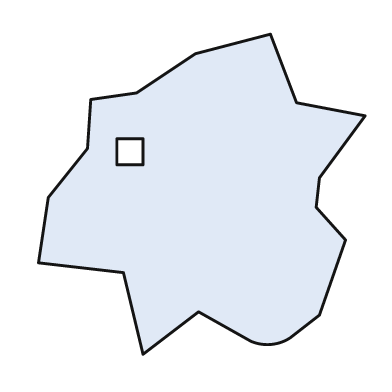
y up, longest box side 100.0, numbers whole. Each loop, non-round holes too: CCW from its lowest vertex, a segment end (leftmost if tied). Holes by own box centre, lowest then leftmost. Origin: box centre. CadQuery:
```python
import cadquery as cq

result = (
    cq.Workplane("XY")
    .moveTo(-18.0, -49.0)
    .lineTo(-1.0, -36.0)
    .lineTo(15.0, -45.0)
    .threePointArc((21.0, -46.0), (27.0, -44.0))
    .lineTo(36.0, -37.0)
    .lineTo(44.0, -14.0)
    .lineTo(35.0, -4.0)
    .lineTo(36.0, 5.0)
    .lineTo(50.0, 24.0)
    .lineTo(29.0, 28.0)
    .lineTo(21.0, 49.0)
    .lineTo(-2.0, 43.0)
    .lineTo(-20.0, 31.0)
    .lineTo(-34.0, 29.0)
    .lineTo(-35.0, 14.0)
    .lineTo(-47.0, -1.0)
    .lineTo(-50.0, -21.0)
    .lineTo(-24.0, -24.0)
    .close()
    .moveTo(-26.0, 9.0)
    .lineTo(-18.0, 9.0)
    .lineTo(-18.0, 17.0)
    .lineTo(-26.0, 17.0)
    .close()
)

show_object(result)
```